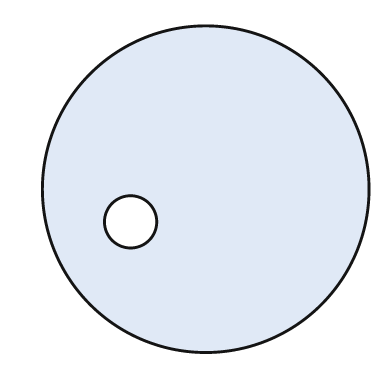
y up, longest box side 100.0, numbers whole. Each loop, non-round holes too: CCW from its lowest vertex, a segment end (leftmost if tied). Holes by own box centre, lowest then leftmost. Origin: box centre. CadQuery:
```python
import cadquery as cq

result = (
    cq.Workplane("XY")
    .moveTo(0.0, 0.0)
    .circle(50.0)
    .moveTo(-23.0, -10.0)
    .circle(8.0)
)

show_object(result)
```